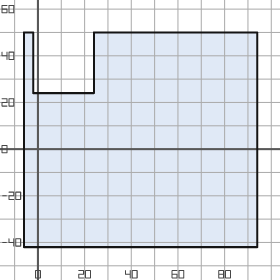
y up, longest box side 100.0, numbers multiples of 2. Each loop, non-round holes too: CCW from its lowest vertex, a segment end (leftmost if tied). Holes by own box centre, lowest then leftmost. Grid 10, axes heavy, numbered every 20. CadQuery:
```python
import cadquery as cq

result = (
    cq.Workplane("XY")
    .moveTo(-6.0, -42.0)
    .lineTo(94.0, -42.0)
    .lineTo(94.0, 50.0)
    .lineTo(24.0, 50.0)
    .lineTo(24.0, 24.0)
    .lineTo(-2.0, 24.0)
    .lineTo(-2.0, 50.0)
    .lineTo(-6.0, 50.0)
    .close()
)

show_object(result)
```